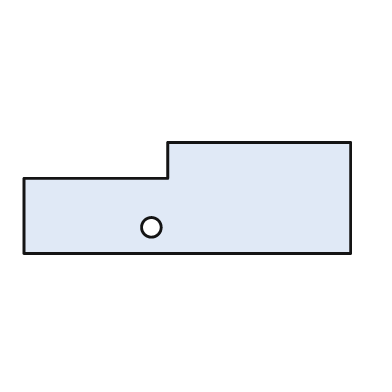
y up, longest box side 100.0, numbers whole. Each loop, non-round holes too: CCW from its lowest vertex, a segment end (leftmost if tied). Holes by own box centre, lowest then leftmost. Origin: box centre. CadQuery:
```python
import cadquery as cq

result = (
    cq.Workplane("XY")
    .moveTo(-50.0, -17.0)
    .lineTo(50.0, -17.0)
    .lineTo(50.0, 17.0)
    .lineTo(-6.0, 17.0)
    .lineTo(-6.0, 6.0)
    .lineTo(-50.0, 6.0)
    .close()
    .moveTo(-11.0, -9.0)
    .circle(3.0)
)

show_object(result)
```